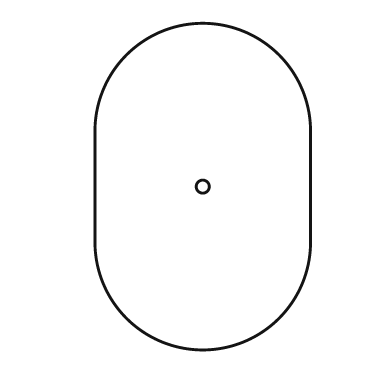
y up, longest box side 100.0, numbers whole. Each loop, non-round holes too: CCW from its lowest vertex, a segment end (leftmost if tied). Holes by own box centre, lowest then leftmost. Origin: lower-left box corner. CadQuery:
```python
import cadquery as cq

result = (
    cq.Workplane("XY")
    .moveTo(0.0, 33.0)
    .threePointArc((33.0, 0.0), (66.0, 33.0))
    .lineTo(66.0, 67.0)
    .threePointArc((33.0, 100.0), (0.0, 67.0))
    .close()
    .moveTo(33.0, 50.0)
    .circle(2.0)
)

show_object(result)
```